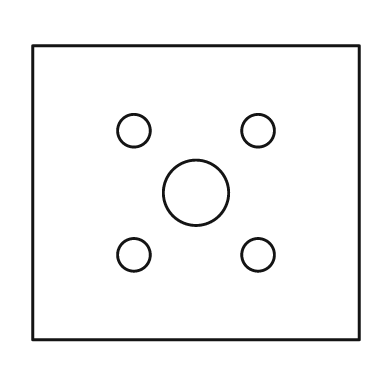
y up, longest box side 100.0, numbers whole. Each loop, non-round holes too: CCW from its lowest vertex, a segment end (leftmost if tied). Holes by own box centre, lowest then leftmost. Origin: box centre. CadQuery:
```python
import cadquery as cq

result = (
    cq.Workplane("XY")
    .moveTo(-50.0, -45.0)
    .lineTo(50.0, -45.0)
    .lineTo(50.0, 45.0)
    .lineTo(-50.0, 45.0)
    .close()
    .moveTo(-19.0, -19.0)
    .circle(5.0)
    .moveTo(19.0, -19.0)
    .circle(5.0)
    .moveTo(0.0, 0.0)
    .circle(10.0)
    .moveTo(-19.0, 19.0)
    .circle(5.0)
    .moveTo(19.0, 19.0)
    .circle(5.0)
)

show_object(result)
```